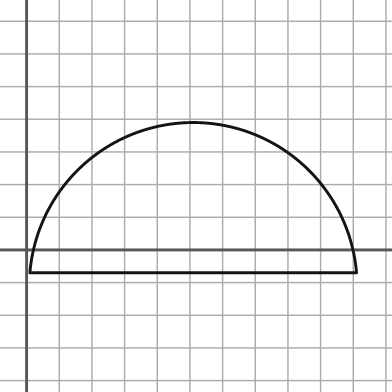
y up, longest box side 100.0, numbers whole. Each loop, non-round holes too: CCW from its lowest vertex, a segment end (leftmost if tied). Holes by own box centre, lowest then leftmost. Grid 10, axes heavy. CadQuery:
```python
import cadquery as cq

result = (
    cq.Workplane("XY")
    .moveTo(1.0, -7.0)
    .lineTo(101.0, -7.0)
    .threePointArc((51.0, 39.0), (1.0, -7.0))
    .close()
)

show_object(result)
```